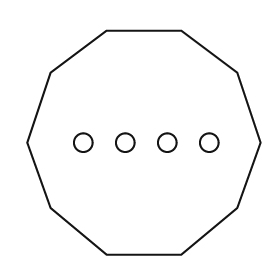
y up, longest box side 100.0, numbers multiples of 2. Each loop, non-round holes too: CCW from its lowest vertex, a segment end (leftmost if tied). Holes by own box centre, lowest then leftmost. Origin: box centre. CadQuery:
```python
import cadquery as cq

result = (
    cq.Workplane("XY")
    .moveTo(-16.0, -48.0)
    .lineTo(16.0, -48.0)
    .lineTo(40.0, -28.0)
    .lineTo(50.0, 0.0)
    .lineTo(40.0, 30.0)
    .lineTo(16.0, 48.0)
    .lineTo(-16.0, 48.0)
    .lineTo(-40.0, 30.0)
    .lineTo(-50.0, 0.0)
    .lineTo(-40.0, -28.0)
    .close()
    .moveTo(-26.0, 0.0)
    .circle(4.0)
    .moveTo(-8.0, 0.0)
    .circle(4.0)
    .moveTo(10.0, 0.0)
    .circle(4.0)
    .moveTo(28.0, 0.0)
    .circle(4.0)
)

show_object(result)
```